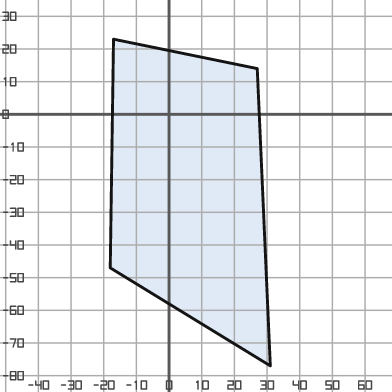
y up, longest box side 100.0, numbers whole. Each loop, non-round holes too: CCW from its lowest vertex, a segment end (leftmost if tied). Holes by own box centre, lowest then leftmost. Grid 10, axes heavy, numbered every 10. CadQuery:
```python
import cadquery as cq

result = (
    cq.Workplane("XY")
    .moveTo(31.0, -77.0)
    .lineTo(27.0, 14.0)
    .lineTo(-17.0, 23.0)
    .lineTo(-18.0, -47.0)
    .close()
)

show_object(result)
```